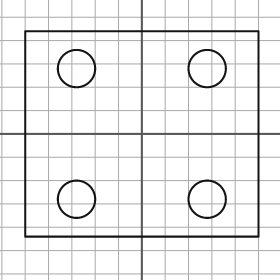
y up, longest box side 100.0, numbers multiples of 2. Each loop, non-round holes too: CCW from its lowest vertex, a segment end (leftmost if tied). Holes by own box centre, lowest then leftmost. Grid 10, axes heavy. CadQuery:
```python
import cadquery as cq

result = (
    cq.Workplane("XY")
    .moveTo(-50.0, -44.0)
    .lineTo(50.0, -44.0)
    .lineTo(50.0, 44.0)
    .lineTo(-50.0, 44.0)
    .close()
    .moveTo(-28.0, -28.0)
    .circle(8.0)
    .moveTo(28.0, -28.0)
    .circle(8.0)
    .moveTo(-28.0, 28.0)
    .circle(8.0)
    .moveTo(28.0, 28.0)
    .circle(8.0)
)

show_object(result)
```